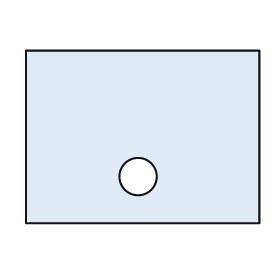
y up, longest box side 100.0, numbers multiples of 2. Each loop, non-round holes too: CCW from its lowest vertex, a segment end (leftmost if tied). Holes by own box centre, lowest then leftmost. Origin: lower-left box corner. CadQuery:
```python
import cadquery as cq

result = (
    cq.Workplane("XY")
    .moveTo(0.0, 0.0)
    .lineTo(100.0, 0.0)
    .lineTo(100.0, 74.0)
    .lineTo(0.0, 74.0)
    .close()
    .moveTo(48.0, 20.0)
    .circle(8.0)
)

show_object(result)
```